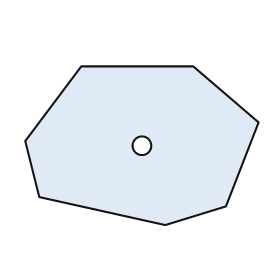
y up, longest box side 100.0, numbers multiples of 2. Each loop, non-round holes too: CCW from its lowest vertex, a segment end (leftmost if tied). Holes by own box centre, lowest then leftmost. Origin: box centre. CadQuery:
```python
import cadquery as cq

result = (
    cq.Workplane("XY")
    .moveTo(10.0, -34.0)
    .lineTo(36.0, -26.0)
    .lineTo(50.0, 10.0)
    .lineTo(22.0, 34.0)
    .lineTo(-26.0, 34.0)
    .lineTo(-50.0, 2.0)
    .lineTo(-44.0, -22.0)
    .close()
    .moveTo(0.0, 0.0)
    .circle(4.0)
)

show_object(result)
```